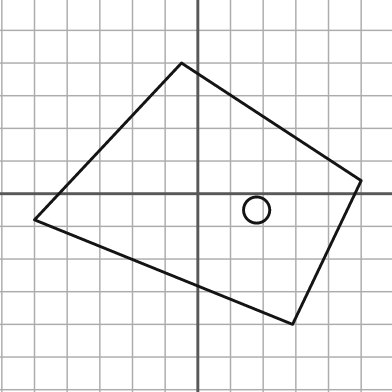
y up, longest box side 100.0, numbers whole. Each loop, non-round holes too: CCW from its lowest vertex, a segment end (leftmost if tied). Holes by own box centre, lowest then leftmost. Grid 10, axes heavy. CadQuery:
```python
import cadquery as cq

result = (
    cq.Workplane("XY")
    .moveTo(29.0, -40.0)
    .lineTo(50.0, 4.0)
    .lineTo(-5.0, 40.0)
    .lineTo(-50.0, -8.0)
    .close()
    .moveTo(18.0, -5.0)
    .circle(4.0)
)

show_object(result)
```